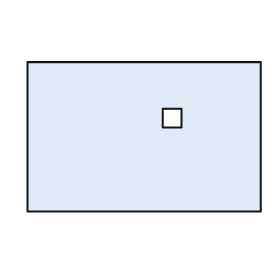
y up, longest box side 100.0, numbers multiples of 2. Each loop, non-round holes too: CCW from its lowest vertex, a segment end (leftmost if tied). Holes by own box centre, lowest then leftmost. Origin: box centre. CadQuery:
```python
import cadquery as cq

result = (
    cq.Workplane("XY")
    .moveTo(-50.0, -32.0)
    .lineTo(50.0, -32.0)
    .lineTo(50.0, 32.0)
    .lineTo(-50.0, 32.0)
    .close()
    .moveTo(8.0, 4.0)
    .lineTo(16.0, 4.0)
    .lineTo(16.0, 12.0)
    .lineTo(8.0, 12.0)
    .close()
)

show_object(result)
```